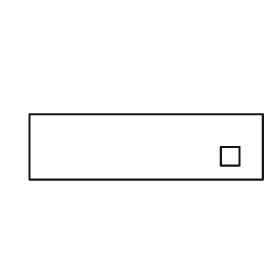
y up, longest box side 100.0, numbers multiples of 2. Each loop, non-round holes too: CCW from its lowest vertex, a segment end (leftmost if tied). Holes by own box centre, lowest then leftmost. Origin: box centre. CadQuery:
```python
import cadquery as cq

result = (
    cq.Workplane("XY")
    .moveTo(-50.0, -14.0)
    .lineTo(50.0, -14.0)
    .lineTo(50.0, 14.0)
    .lineTo(-50.0, 14.0)
    .close()
    .moveTo(32.0, -8.0)
    .lineTo(40.0, -8.0)
    .lineTo(40.0, 0.0)
    .lineTo(32.0, 0.0)
    .close()
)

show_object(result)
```